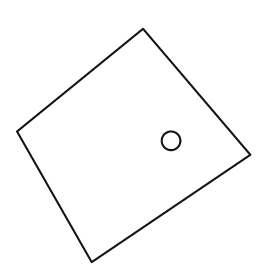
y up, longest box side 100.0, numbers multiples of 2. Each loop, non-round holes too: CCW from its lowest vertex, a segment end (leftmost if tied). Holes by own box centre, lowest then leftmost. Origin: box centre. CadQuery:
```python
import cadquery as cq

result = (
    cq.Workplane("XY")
    .moveTo(-18.0, -50.0)
    .lineTo(50.0, -4.0)
    .lineTo(4.0, 50.0)
    .lineTo(-50.0, 6.0)
    .close()
    .moveTo(16.0, 2.0)
    .circle(4.0)
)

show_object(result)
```